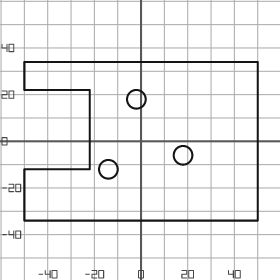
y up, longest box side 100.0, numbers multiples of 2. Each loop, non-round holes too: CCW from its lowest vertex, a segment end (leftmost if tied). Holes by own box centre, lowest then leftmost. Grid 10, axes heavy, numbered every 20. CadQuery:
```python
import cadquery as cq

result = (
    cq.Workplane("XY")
    .moveTo(-50.0, -34.0)
    .lineTo(50.0, -34.0)
    .lineTo(50.0, 34.0)
    .lineTo(-50.0, 34.0)
    .lineTo(-50.0, 22.0)
    .lineTo(-22.0, 22.0)
    .lineTo(-22.0, -12.0)
    .lineTo(-50.0, -12.0)
    .close()
    .moveTo(-14.0, -12.0)
    .circle(4.0)
    .moveTo(18.0, -6.0)
    .circle(4.0)
    .moveTo(-2.0, 18.0)
    .circle(4.0)
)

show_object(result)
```